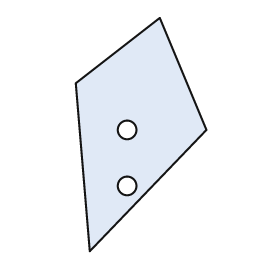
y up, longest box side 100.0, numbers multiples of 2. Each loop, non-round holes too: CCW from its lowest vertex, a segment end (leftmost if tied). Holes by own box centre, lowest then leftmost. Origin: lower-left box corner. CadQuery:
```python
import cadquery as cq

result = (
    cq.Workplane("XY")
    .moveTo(6.0, 0.0)
    .lineTo(56.0, 52.0)
    .lineTo(36.0, 100.0)
    .lineTo(0.0, 72.0)
    .close()
    .moveTo(22.0, 28.0)
    .circle(4.0)
    .moveTo(22.0, 52.0)
    .circle(4.0)
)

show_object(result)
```